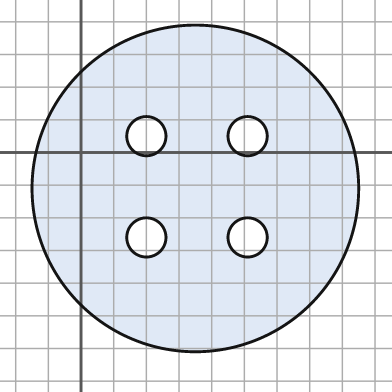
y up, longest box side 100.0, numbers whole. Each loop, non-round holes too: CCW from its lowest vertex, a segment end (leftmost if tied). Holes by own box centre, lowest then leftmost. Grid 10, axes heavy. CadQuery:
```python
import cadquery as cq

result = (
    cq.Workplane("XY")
    .moveTo(35.0, -11.0)
    .circle(50.0)
    .moveTo(20.0, -26.0)
    .circle(6.0)
    .moveTo(51.0, -26.0)
    .circle(6.0)
    .moveTo(20.0, 5.0)
    .circle(6.0)
    .moveTo(51.0, 5.0)
    .circle(6.0)
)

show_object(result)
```